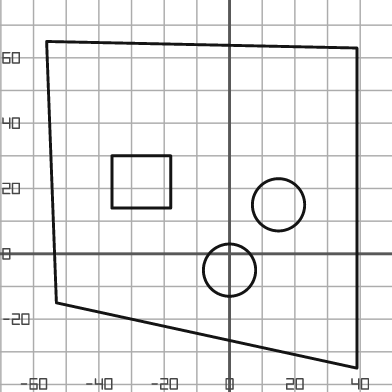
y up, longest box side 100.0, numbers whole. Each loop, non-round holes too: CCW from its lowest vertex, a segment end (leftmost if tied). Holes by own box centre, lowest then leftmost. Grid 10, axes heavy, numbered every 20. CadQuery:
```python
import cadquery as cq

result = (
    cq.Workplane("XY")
    .moveTo(39.0, -35.0)
    .lineTo(39.0, 63.0)
    .lineTo(-56.0, 65.0)
    .lineTo(-53.0, -15.0)
    .close()
    .moveTo(0.0, -5.0)
    .circle(8.0)
    .moveTo(15.0, 15.0)
    .circle(8.0)
    .moveTo(-36.0, 14.0)
    .lineTo(-18.0, 14.0)
    .lineTo(-18.0, 30.0)
    .lineTo(-36.0, 30.0)
    .close()
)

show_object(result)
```